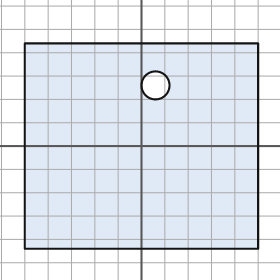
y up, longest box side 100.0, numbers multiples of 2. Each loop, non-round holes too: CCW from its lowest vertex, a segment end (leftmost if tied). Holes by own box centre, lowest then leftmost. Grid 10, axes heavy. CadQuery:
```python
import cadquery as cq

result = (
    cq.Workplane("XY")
    .moveTo(-50.0, -44.0)
    .lineTo(50.0, -44.0)
    .lineTo(50.0, 44.0)
    .lineTo(-50.0, 44.0)
    .close()
    .moveTo(6.0, 26.0)
    .circle(6.0)
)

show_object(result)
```